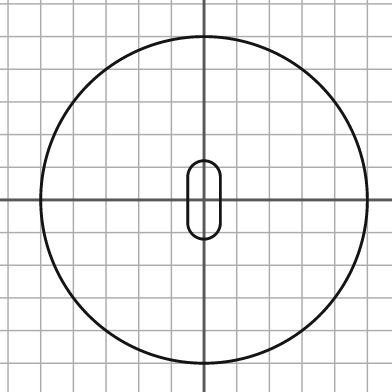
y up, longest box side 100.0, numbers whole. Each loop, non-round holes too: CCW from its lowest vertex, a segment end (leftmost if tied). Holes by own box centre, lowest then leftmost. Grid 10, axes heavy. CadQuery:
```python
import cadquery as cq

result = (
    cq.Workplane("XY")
    .moveTo(0.0, 0.0)
    .circle(50.0)
    .moveTo(-5.0, -7.0)
    .threePointArc((0.0, -12.0), (5.0, -7.0))
    .lineTo(5.0, 7.0)
    .threePointArc((0.0, 12.0), (-5.0, 7.0))
    .close()
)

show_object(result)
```